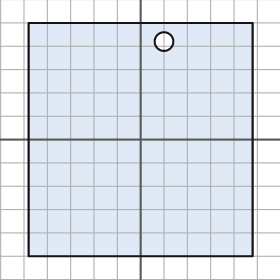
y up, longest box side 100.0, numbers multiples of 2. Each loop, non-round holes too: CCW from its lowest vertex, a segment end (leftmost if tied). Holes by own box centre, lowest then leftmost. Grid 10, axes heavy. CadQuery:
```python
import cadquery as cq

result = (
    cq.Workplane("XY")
    .moveTo(-48.0, -50.0)
    .lineTo(48.0, -50.0)
    .lineTo(48.0, 50.0)
    .lineTo(-48.0, 50.0)
    .close()
    .moveTo(10.0, 42.0)
    .circle(4.0)
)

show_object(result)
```